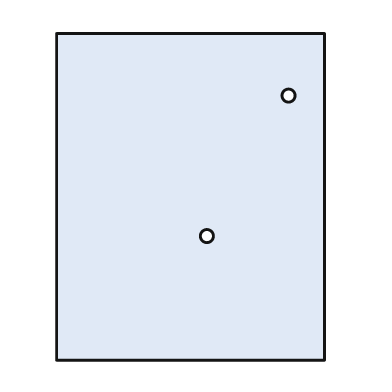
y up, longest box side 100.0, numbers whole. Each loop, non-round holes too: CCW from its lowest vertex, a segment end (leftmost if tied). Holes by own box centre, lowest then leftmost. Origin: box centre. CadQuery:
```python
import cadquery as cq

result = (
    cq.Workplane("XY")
    .moveTo(-41.0, -50.0)
    .lineTo(41.0, -50.0)
    .lineTo(41.0, 50.0)
    .lineTo(-41.0, 50.0)
    .close()
    .moveTo(5.0, -12.0)
    .circle(2.0)
    .moveTo(30.0, 31.0)
    .circle(2.0)
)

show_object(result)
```